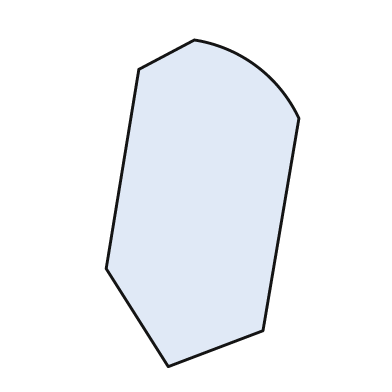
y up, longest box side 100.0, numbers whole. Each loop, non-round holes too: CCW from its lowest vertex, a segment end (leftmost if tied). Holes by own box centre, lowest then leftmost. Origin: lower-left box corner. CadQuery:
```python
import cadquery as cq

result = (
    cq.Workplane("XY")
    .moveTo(19.0, 0.0)
    .lineTo(48.0, 11.0)
    .lineTo(59.0, 76.0)
    .threePointArc((46.0, 92.0), (27.0, 100.0))
    .lineTo(10.0, 91.0)
    .lineTo(0.0, 30.0)
    .close()
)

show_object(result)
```